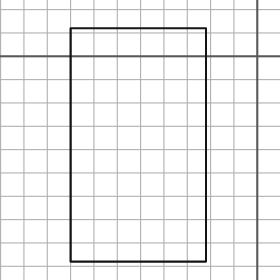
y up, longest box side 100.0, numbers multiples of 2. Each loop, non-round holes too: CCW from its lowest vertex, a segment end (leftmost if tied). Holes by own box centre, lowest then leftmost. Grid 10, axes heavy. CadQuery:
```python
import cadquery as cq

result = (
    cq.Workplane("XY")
    .moveTo(-80.0, -88.0)
    .lineTo(-22.0, -88.0)
    .lineTo(-22.0, 12.0)
    .lineTo(-80.0, 12.0)
    .close()
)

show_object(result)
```